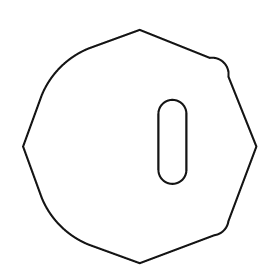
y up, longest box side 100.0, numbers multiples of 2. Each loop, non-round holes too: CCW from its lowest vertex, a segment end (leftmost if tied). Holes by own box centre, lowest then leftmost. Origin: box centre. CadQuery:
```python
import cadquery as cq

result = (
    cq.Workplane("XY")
    .moveTo(0.0, -50.0)
    .lineTo(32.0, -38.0)
    .threePointArc((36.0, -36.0), (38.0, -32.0))
    .lineTo(50.0, 0.0)
    .lineTo(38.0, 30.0)
    .threePointArc((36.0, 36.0), (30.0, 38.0))
    .lineTo(0.0, 50.0)
    .lineTo(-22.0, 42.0)
    .threePointArc((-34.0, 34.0), (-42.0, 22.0))
    .lineTo(-50.0, 0.0)
    .lineTo(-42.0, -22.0)
    .threePointArc((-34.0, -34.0), (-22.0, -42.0))
    .close()
    .moveTo(8.0, -10.0)
    .threePointArc((14.0, -16.0), (20.0, -10.0))
    .lineTo(20.0, 14.0)
    .threePointArc((14.0, 20.0), (8.0, 14.0))
    .close()
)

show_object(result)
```